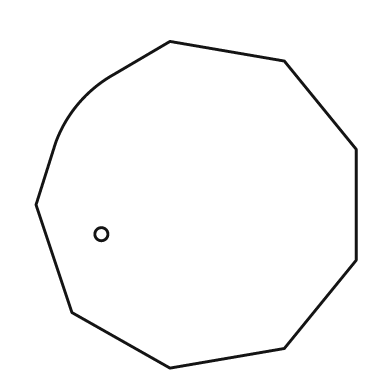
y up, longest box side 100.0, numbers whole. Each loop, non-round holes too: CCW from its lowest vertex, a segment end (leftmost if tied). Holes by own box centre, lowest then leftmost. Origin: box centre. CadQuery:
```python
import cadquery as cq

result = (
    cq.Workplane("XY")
    .moveTo(-8.0, -50.0)
    .lineTo(27.0, -44.0)
    .lineTo(49.0, -17.0)
    .lineTo(49.0, 17.0)
    .lineTo(27.0, 44.0)
    .lineTo(-8.0, 50.0)
    .lineTo(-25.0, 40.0)
    .threePointArc((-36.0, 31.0), (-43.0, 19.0))
    .lineTo(-49.0, 0.0)
    .lineTo(-38.0, -33.0)
    .close()
    .moveTo(-29.0, -9.0)
    .circle(2.0)
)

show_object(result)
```